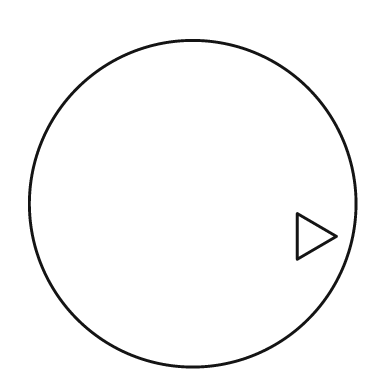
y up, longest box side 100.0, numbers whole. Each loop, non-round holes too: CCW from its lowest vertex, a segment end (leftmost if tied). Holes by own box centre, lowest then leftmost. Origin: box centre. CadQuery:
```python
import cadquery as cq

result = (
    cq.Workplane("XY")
    .moveTo(0.0, 0.0)
    .circle(50.0)
    .moveTo(32.0, -17.0)
    .lineTo(44.0, -10.0)
    .lineTo(32.0, -3.0)
    .close()
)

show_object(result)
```